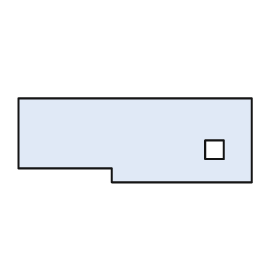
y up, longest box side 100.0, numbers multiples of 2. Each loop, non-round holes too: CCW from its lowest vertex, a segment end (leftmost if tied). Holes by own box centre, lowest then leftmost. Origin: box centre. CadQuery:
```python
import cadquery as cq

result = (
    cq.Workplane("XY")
    .moveTo(-10.0, -18.0)
    .lineTo(50.0, -18.0)
    .lineTo(50.0, 18.0)
    .lineTo(-50.0, 18.0)
    .lineTo(-50.0, -12.0)
    .lineTo(-10.0, -12.0)
    .close()
    .moveTo(30.0, -8.0)
    .lineTo(38.0, -8.0)
    .lineTo(38.0, 0.0)
    .lineTo(30.0, 0.0)
    .close()
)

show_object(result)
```